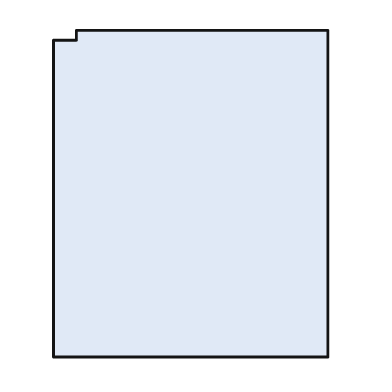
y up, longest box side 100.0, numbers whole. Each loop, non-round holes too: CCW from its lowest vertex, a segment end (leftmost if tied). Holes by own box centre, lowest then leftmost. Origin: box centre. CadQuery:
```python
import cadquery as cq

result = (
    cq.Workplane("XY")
    .moveTo(-42.0, -50.0)
    .lineTo(42.0, -50.0)
    .lineTo(42.0, 50.0)
    .lineTo(-35.0, 50.0)
    .lineTo(-35.0, 47.0)
    .lineTo(-42.0, 47.0)
    .close()
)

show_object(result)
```